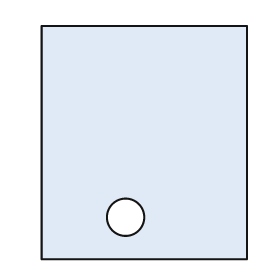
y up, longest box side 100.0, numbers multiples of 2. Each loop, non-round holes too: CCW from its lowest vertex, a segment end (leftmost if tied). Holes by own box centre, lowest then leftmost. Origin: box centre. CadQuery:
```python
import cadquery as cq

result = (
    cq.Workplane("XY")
    .moveTo(-44.0, -50.0)
    .lineTo(44.0, -50.0)
    .lineTo(44.0, 50.0)
    .lineTo(-44.0, 50.0)
    .close()
    .moveTo(-8.0, -32.0)
    .circle(8.0)
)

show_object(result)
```